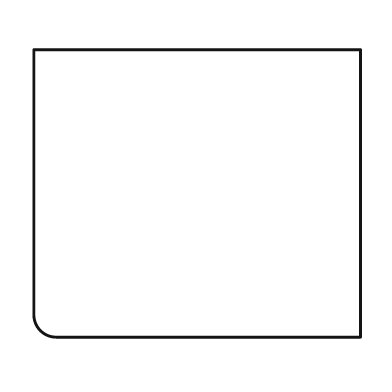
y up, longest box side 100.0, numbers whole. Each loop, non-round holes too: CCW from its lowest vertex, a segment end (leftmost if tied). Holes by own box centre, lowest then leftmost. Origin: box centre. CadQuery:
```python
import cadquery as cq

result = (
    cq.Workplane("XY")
    .moveTo(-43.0, -44.0)
    .lineTo(50.0, -44.0)
    .lineTo(50.0, 44.0)
    .lineTo(-50.0, 44.0)
    .lineTo(-50.0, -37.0)
    .threePointArc((-48.0, -42.0), (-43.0, -44.0))
    .close()
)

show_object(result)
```